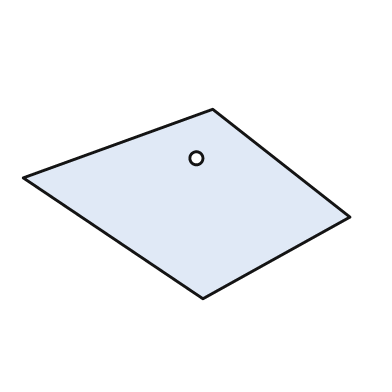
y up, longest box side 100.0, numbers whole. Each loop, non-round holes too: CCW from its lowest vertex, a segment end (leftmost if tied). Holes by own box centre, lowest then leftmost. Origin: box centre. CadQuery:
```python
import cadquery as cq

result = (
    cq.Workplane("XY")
    .moveTo(5.0, -29.0)
    .lineTo(50.0, -4.0)
    .lineTo(8.0, 29.0)
    .lineTo(-50.0, 8.0)
    .close()
    .moveTo(3.0, 14.0)
    .circle(2.0)
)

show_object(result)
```